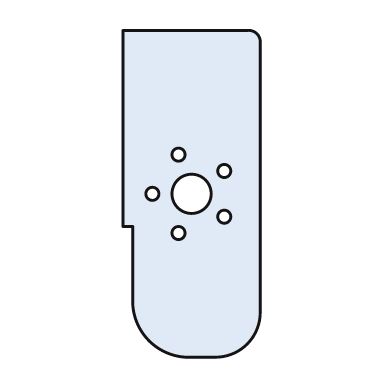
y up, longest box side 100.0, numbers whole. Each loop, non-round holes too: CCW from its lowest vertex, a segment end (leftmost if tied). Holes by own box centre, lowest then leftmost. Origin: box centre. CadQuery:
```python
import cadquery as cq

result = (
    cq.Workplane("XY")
    .moveTo(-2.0, -50.0)
    .lineTo(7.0, -50.0)
    .threePointArc((17.0, -46.0), (21.0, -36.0))
    .lineTo(21.0, 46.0)
    .threePointArc((20.0, 49.0), (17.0, 50.0))
    .lineTo(-21.0, 50.0)
    .lineTo(-21.0, -10.0)
    .lineTo(-18.0, -10.0)
    .lineTo(-18.0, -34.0)
    .threePointArc((-13.0, -45.0), (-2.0, -50.0))
    .close()
    .moveTo(-4.0, -12.0)
    .circle(2.0)
    .moveTo(10.0, -7.0)
    .circle(2.0)
    .moveTo(-12.0, 0.0)
    .circle(2.0)
    .moveTo(0.0, 0.0)
    .circle(6.0)
    .moveTo(10.0, 7.0)
    .circle(2.0)
    .moveTo(-4.0, 12.0)
    .circle(2.0)
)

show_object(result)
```